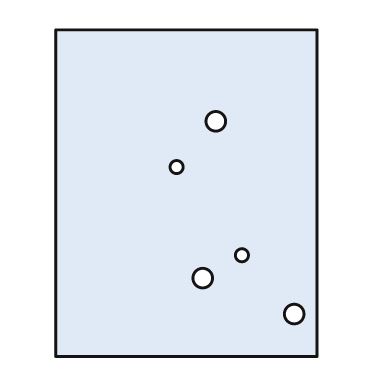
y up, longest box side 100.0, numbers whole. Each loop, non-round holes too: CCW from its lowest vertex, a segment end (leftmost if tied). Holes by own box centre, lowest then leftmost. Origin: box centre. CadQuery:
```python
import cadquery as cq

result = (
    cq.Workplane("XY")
    .moveTo(-40.0, -50.0)
    .lineTo(40.0, -50.0)
    .lineTo(40.0, 50.0)
    .lineTo(-40.0, 50.0)
    .close()
    .moveTo(33.0, -37.0)
    .circle(3.0)
    .moveTo(5.0, -26.0)
    .circle(3.0)
    .moveTo(17.0, -19.0)
    .circle(2.0)
    .moveTo(-3.0, 8.0)
    .circle(2.0)
    .moveTo(9.0, 22.0)
    .circle(3.0)
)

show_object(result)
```